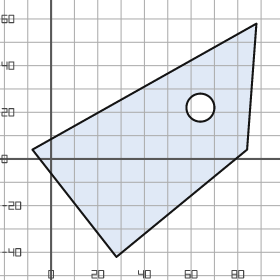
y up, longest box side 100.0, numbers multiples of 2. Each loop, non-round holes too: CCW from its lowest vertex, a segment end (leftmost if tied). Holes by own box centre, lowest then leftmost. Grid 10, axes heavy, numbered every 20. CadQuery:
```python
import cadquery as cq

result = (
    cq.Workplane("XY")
    .moveTo(28.0, -42.0)
    .lineTo(84.0, 4.0)
    .lineTo(88.0, 58.0)
    .lineTo(-8.0, 4.0)
    .close()
    .moveTo(64.0, 22.0)
    .circle(6.0)
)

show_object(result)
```